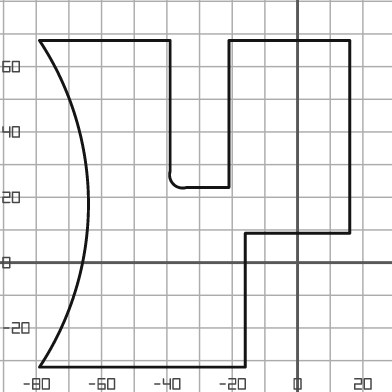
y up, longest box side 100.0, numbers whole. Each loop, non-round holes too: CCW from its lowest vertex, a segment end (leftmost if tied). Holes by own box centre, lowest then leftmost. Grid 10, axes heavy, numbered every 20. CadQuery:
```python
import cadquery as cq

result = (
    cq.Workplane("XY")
    .moveTo(-79.0, -32.0)
    .lineTo(-16.0, -32.0)
    .lineTo(-16.0, 9.0)
    .lineTo(16.0, 9.0)
    .lineTo(16.0, 68.0)
    .lineTo(-21.0, 68.0)
    .lineTo(-21.0, 23.0)
    .lineTo(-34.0, 23.0)
    .threePointArc((-38.0, 24.0), (-39.0, 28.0))
    .lineTo(-39.0, 68.0)
    .lineTo(-79.0, 68.0)
    .threePointArc((-64.0, 18.0), (-79.0, -32.0))
    .close()
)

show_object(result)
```